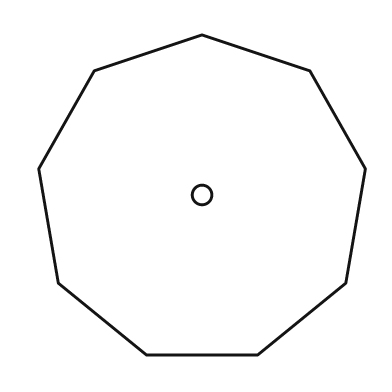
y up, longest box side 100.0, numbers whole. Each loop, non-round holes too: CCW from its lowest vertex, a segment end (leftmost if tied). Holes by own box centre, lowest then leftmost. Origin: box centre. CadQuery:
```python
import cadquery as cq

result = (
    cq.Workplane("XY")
    .moveTo(-17.0, -49.0)
    .lineTo(17.0, -49.0)
    .lineTo(44.0, -27.0)
    .lineTo(50.0, 8.0)
    .lineTo(33.0, 38.0)
    .lineTo(0.0, 49.0)
    .lineTo(-33.0, 38.0)
    .lineTo(-50.0, 8.0)
    .lineTo(-44.0, -27.0)
    .close()
    .moveTo(0.0, 0.0)
    .circle(3.0)
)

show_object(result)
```